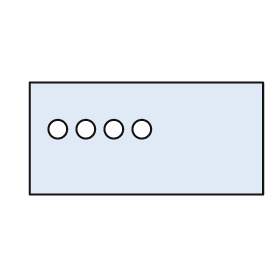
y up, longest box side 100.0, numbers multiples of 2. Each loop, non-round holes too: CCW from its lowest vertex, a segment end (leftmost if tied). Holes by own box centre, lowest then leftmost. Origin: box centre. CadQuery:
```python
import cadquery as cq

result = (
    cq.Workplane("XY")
    .moveTo(-50.0, -24.0)
    .lineTo(50.0, -24.0)
    .lineTo(50.0, 24.0)
    .lineTo(-50.0, 24.0)
    .close()
    .moveTo(-38.0, 4.0)
    .circle(4.0)
    .moveTo(-26.0, 4.0)
    .circle(4.0)
    .moveTo(-14.0, 4.0)
    .circle(4.0)
    .moveTo(-2.0, 4.0)
    .circle(4.0)
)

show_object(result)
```